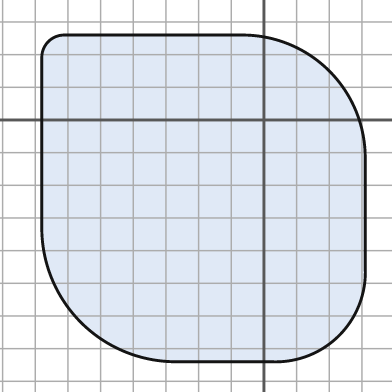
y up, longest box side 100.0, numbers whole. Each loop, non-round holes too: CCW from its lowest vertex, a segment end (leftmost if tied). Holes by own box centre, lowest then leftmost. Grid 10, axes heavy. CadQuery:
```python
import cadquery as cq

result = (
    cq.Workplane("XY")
    .moveTo(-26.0, -74.0)
    .lineTo(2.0, -74.0)
    .threePointArc((23.0, -66.0), (31.0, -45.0))
    .lineTo(31.0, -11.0)
    .threePointArc((20.0, 15.0), (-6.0, 26.0))
    .lineTo(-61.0, 26.0)
    .threePointArc((-66.0, 24.0), (-68.0, 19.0))
    .lineTo(-68.0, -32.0)
    .threePointArc((-56.0, -62.0), (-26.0, -74.0))
    .close()
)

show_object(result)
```